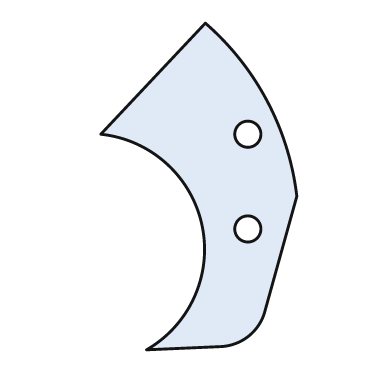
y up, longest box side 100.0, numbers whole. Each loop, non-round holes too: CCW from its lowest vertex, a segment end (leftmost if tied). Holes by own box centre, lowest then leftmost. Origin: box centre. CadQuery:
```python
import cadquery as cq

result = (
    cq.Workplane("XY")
    .moveTo(-16.0, -50.0)
    .lineTo(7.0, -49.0)
    .threePointArc((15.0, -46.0), (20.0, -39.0))
    .lineTo(30.0, -3.0)
    .threePointArc((21.0, 26.0), (2.0, 50.0))
    .lineTo(-30.0, 16.0)
    .threePointArc((1.0, -12.0), (-16.0, -50.0))
    .close()
    .moveTo(15.0, -13.0)
    .circle(4.0)
    .moveTo(15.0, 16.0)
    .circle(4.0)
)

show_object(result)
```